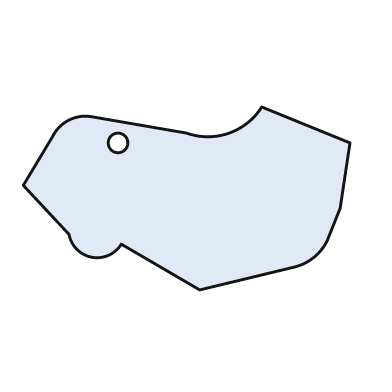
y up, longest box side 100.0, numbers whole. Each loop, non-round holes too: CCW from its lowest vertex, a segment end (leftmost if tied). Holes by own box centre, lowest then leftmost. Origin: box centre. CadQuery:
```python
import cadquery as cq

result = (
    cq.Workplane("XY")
    .moveTo(4.0, -28.0)
    .lineTo(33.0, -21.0)
    .threePointArc((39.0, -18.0), (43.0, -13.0))
    .lineTo(47.0, -3.0)
    .lineTo(50.0, 17.0)
    .lineTo(23.0, 28.0)
    .threePointArc((13.0, 20.0), (0.0, 20.0))
    .lineTo(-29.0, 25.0)
    .threePointArc((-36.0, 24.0), (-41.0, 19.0))
    .lineTo(-50.0, 4.0)
    .lineTo(-36.0, -11.0)
    .threePointArc((-29.0, -18.0), (-20.0, -14.0))
    .close()
    .moveTo(-21.0, 17.0)
    .circle(3.0)
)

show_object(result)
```